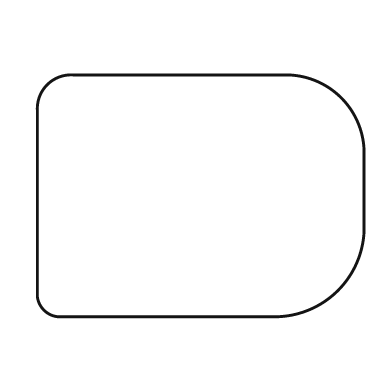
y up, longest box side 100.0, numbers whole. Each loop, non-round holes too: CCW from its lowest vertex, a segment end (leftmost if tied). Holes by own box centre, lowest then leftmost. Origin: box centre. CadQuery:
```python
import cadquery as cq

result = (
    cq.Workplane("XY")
    .moveTo(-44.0, -37.0)
    .lineTo(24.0, -37.0)
    .threePointArc((42.0, -29.0), (50.0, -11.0))
    .lineTo(50.0, 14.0)
    .threePointArc((43.0, 30.0), (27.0, 37.0))
    .lineTo(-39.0, 37.0)
    .threePointArc((-47.0, 34.0), (-50.0, 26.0))
    .lineTo(-50.0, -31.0)
    .threePointArc((-48.0, -35.0), (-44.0, -37.0))
    .close()
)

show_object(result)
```